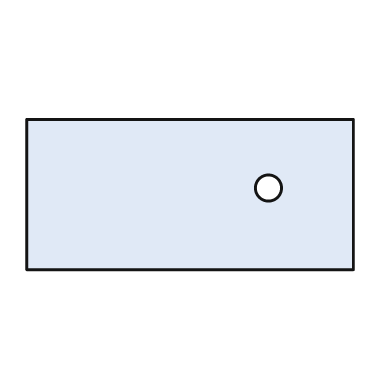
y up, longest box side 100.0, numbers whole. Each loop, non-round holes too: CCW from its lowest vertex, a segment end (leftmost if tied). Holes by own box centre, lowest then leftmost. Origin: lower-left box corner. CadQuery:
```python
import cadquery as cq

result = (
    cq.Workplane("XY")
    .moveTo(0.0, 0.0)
    .lineTo(100.0, 0.0)
    .lineTo(100.0, 46.0)
    .lineTo(0.0, 46.0)
    .close()
    .moveTo(74.0, 25.0)
    .circle(4.0)
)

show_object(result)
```